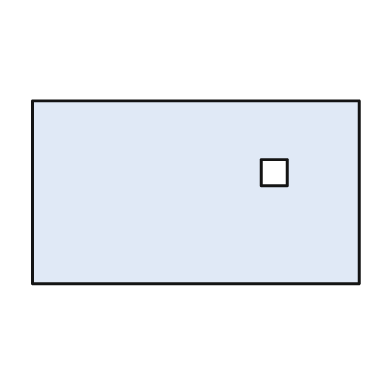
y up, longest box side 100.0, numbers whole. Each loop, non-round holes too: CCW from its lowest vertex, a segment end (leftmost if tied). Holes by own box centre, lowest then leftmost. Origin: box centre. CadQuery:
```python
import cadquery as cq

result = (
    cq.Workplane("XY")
    .moveTo(-50.0, -28.0)
    .lineTo(50.0, -28.0)
    .lineTo(50.0, 28.0)
    .lineTo(-50.0, 28.0)
    .close()
    .moveTo(20.0, 2.0)
    .lineTo(28.0, 2.0)
    .lineTo(28.0, 10.0)
    .lineTo(20.0, 10.0)
    .close()
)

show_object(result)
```